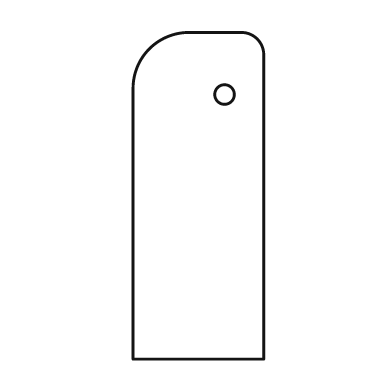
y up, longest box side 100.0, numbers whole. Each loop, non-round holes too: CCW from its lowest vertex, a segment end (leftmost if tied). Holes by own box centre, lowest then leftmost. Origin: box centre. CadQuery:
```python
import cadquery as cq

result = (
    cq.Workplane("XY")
    .moveTo(-20.0, -50.0)
    .lineTo(20.0, -50.0)
    .lineTo(20.0, 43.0)
    .threePointArc((18.0, 48.0), (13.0, 50.0))
    .lineTo(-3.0, 50.0)
    .threePointArc((-15.0, 45.0), (-20.0, 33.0))
    .close()
    .moveTo(8.0, 31.0)
    .circle(3.0)
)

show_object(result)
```